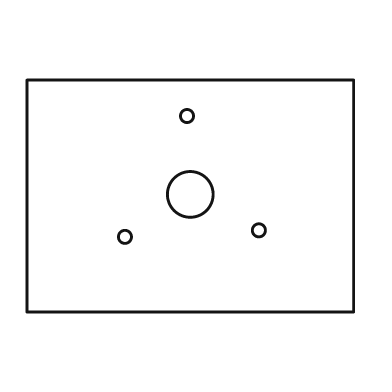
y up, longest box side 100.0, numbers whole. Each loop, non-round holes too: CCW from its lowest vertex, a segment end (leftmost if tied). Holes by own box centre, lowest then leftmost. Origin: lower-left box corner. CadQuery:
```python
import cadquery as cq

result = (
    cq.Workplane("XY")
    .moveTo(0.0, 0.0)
    .lineTo(100.0, 0.0)
    .lineTo(100.0, 71.0)
    .lineTo(0.0, 71.0)
    .close()
    .moveTo(30.0, 23.0)
    .circle(2.0)
    .moveTo(71.0, 25.0)
    .circle(2.0)
    .moveTo(50.0, 36.0)
    .circle(7.0)
    .moveTo(49.0, 60.0)
    .circle(2.0)
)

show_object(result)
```